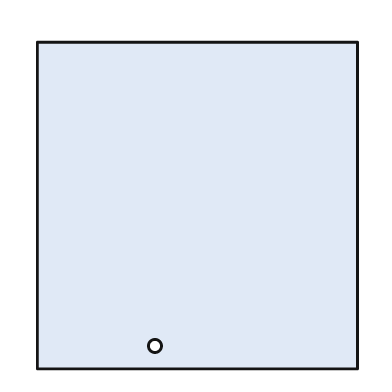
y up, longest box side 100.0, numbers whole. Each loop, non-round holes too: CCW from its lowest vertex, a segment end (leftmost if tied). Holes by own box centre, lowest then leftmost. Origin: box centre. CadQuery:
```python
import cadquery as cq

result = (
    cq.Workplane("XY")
    .moveTo(-49.0, -50.0)
    .lineTo(49.0, -50.0)
    .lineTo(49.0, 50.0)
    .lineTo(-49.0, 50.0)
    .close()
    .moveTo(-13.0, -43.0)
    .circle(2.0)
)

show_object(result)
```